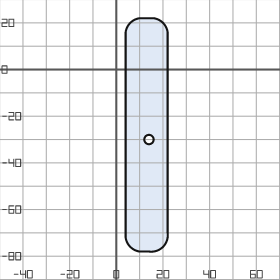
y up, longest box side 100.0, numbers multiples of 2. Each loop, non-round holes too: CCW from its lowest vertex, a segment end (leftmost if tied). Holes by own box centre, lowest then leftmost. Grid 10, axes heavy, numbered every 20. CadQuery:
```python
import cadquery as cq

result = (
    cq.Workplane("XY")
    .moveTo(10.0, -78.0)
    .lineTo(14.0, -78.0)
    .threePointArc((20.0, -76.0), (22.0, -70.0))
    .lineTo(22.0, 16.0)
    .threePointArc((20.0, 20.0), (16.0, 22.0))
    .lineTo(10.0, 22.0)
    .threePointArc((6.0, 20.0), (4.0, 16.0))
    .lineTo(4.0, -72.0)
    .threePointArc((6.0, -76.0), (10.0, -78.0))
    .close()
    .moveTo(14.0, -30.0)
    .circle(2.0)
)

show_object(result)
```